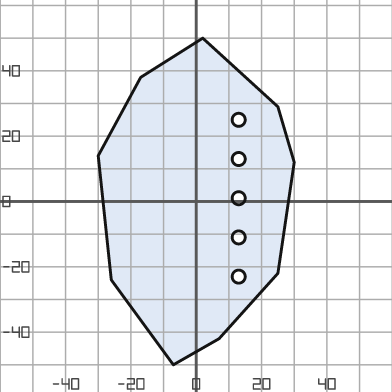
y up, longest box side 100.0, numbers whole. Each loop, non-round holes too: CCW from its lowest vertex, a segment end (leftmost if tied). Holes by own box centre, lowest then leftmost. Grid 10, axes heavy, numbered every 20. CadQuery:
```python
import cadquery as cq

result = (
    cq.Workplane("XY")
    .moveTo(-7.0, -50.0)
    .lineTo(7.0, -42.0)
    .lineTo(25.0, -22.0)
    .lineTo(30.0, 12.0)
    .lineTo(25.0, 29.0)
    .lineTo(2.0, 50.0)
    .lineTo(-17.0, 38.0)
    .lineTo(-30.0, 14.0)
    .lineTo(-26.0, -24.0)
    .close()
    .moveTo(13.0, -23.0)
    .circle(2.0)
    .moveTo(13.0, -11.0)
    .circle(2.0)
    .moveTo(13.0, 1.0)
    .circle(2.0)
    .moveTo(13.0, 13.0)
    .circle(2.0)
    .moveTo(13.0, 25.0)
    .circle(2.0)
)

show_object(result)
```